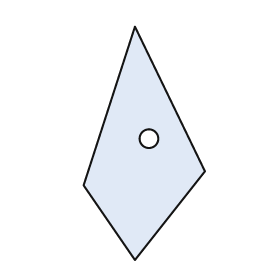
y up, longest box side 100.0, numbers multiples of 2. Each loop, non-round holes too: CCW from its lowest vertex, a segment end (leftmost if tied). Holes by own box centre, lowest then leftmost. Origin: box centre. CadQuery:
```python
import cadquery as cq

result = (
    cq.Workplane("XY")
    .moveTo(-4.0, -50.0)
    .lineTo(26.0, -12.0)
    .lineTo(-4.0, 50.0)
    .lineTo(-26.0, -18.0)
    .close()
    .moveTo(2.0, 2.0)
    .circle(4.0)
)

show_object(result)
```